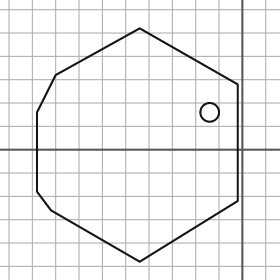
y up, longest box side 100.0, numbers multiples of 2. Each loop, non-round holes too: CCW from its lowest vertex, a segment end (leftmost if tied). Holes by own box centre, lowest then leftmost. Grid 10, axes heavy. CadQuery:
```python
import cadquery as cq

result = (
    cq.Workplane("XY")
    .moveTo(-44.0, -48.0)
    .lineTo(-2.0, -22.0)
    .lineTo(-2.0, 28.0)
    .lineTo(-44.0, 52.0)
    .lineTo(-80.0, 32.0)
    .lineTo(-88.0, 16.0)
    .lineTo(-88.0, -18.0)
    .lineTo(-82.0, -26.0)
    .close()
    .moveTo(-14.0, 16.0)
    .circle(4.0)
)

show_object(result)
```